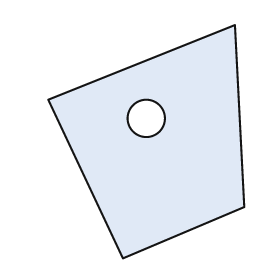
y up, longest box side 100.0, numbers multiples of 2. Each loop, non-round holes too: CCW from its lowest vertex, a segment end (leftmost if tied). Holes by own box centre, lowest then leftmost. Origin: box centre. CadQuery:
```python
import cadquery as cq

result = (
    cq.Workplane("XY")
    .moveTo(-10.0, -50.0)
    .lineTo(42.0, -28.0)
    .lineTo(38.0, 50.0)
    .lineTo(-42.0, 18.0)
    .close()
    .moveTo(0.0, 10.0)
    .circle(8.0)
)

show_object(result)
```